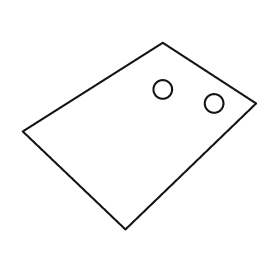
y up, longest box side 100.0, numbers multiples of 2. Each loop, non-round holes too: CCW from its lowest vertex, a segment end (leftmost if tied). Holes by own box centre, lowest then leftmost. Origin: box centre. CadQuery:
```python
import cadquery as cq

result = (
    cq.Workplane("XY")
    .moveTo(-6.0, -40.0)
    .lineTo(50.0, 14.0)
    .lineTo(10.0, 40.0)
    .lineTo(-50.0, 2.0)
    .close()
    .moveTo(32.0, 14.0)
    .circle(4.0)
    .moveTo(10.0, 20.0)
    .circle(4.0)
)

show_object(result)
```